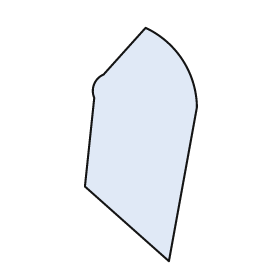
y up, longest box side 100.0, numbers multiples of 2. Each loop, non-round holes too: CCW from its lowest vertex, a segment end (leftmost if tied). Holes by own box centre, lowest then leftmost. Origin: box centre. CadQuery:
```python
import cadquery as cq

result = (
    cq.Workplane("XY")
    .moveTo(12.0, -50.0)
    .lineTo(24.0, 16.0)
    .threePointArc((18.0, 36.0), (2.0, 50.0))
    .lineTo(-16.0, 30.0)
    .threePointArc((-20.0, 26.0), (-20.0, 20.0))
    .lineTo(-24.0, -18.0)
    .close()
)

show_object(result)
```